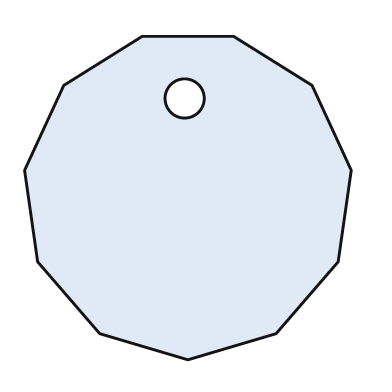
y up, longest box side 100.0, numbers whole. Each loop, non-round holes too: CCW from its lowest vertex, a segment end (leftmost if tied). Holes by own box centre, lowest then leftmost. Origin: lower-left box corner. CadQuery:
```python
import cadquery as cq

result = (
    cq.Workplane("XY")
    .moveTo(50.0, 0.0)
    .lineTo(77.0, 8.0)
    .lineTo(96.0, 30.0)
    .lineTo(100.0, 58.0)
    .lineTo(88.0, 84.0)
    .lineTo(64.0, 99.0)
    .lineTo(36.0, 99.0)
    .lineTo(12.0, 84.0)
    .lineTo(0.0, 58.0)
    .lineTo(4.0, 30.0)
    .lineTo(23.0, 8.0)
    .close()
    .moveTo(49.0, 80.0)
    .circle(6.0)
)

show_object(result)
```